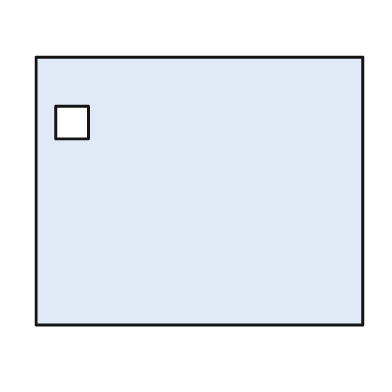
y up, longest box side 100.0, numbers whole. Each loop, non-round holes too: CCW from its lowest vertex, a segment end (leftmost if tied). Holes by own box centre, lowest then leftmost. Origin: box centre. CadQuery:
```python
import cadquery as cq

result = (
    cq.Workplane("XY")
    .moveTo(-50.0, -41.0)
    .lineTo(50.0, -41.0)
    .lineTo(50.0, 41.0)
    .lineTo(-50.0, 41.0)
    .close()
    .moveTo(-44.0, 16.0)
    .lineTo(-34.0, 16.0)
    .lineTo(-34.0, 26.0)
    .lineTo(-44.0, 26.0)
    .close()
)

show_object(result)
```